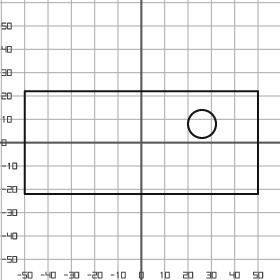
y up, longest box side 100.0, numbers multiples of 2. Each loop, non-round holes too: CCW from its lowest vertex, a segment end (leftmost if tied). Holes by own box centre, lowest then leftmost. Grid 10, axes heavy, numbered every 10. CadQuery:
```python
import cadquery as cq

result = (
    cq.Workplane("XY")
    .moveTo(-50.0, -22.0)
    .lineTo(50.0, -22.0)
    .lineTo(50.0, 22.0)
    .lineTo(-50.0, 22.0)
    .close()
    .moveTo(26.0, 8.0)
    .circle(6.0)
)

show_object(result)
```